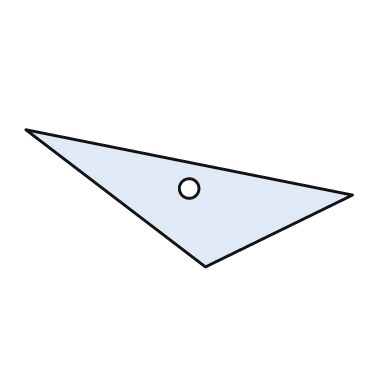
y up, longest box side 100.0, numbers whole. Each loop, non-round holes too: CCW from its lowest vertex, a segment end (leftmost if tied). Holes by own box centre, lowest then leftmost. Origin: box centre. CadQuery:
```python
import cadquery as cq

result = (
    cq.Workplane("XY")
    .moveTo(5.0, -21.0)
    .lineTo(50.0, 1.0)
    .lineTo(-50.0, 21.0)
    .close()
    .moveTo(0.0, 3.0)
    .circle(3.0)
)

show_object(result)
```